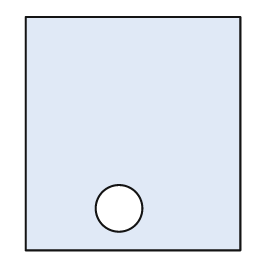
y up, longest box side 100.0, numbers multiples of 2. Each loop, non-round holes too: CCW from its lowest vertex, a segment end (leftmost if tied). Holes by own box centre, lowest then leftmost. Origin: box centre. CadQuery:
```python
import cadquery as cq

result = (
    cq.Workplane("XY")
    .moveTo(-46.0, -50.0)
    .lineTo(46.0, -50.0)
    .lineTo(46.0, 50.0)
    .lineTo(-46.0, 50.0)
    .close()
    .moveTo(-6.0, -32.0)
    .circle(10.0)
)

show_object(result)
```